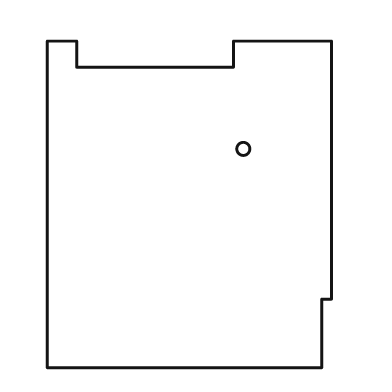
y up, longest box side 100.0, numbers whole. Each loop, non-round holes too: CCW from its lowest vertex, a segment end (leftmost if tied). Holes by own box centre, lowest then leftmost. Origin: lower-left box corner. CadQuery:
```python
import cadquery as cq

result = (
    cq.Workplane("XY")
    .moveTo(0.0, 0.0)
    .lineTo(84.0, 0.0)
    .lineTo(84.0, 21.0)
    .lineTo(87.0, 21.0)
    .lineTo(87.0, 100.0)
    .lineTo(57.0, 100.0)
    .lineTo(57.0, 92.0)
    .lineTo(9.0, 92.0)
    .lineTo(9.0, 100.0)
    .lineTo(0.0, 100.0)
    .close()
    .moveTo(60.0, 67.0)
    .circle(2.0)
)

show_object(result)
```